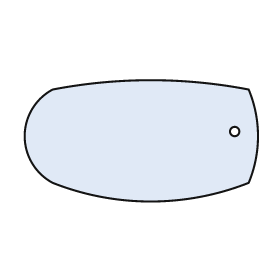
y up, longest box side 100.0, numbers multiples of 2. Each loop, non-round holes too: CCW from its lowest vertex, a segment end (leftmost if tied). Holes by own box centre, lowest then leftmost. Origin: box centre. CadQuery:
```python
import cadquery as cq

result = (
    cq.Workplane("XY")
    .moveTo(-38.0, -18.0)
    .threePointArc((4.0, -26.0), (46.0, -18.0))
    .threePointArc((50.0, 2.0), (46.0, 22.0))
    .threePointArc((4.0, 26.0), (-38.0, 22.0))
    .threePointArc((-50.0, 2.0), (-38.0, -18.0))
    .close()
    .moveTo(40.0, 4.0)
    .circle(2.0)
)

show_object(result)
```